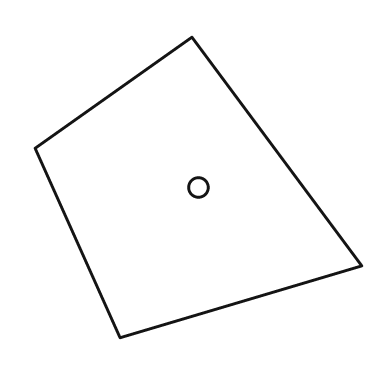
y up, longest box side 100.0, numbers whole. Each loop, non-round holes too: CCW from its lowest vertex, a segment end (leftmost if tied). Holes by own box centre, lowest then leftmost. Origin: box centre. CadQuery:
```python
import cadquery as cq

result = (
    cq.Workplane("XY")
    .moveTo(-24.0, -46.0)
    .lineTo(50.0, -24.0)
    .lineTo(-2.0, 46.0)
    .lineTo(-50.0, 12.0)
    .close()
    .moveTo(0.0, 0.0)
    .circle(3.0)
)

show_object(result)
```